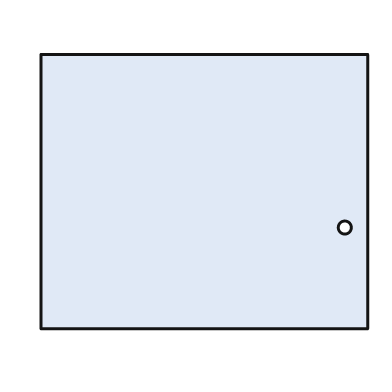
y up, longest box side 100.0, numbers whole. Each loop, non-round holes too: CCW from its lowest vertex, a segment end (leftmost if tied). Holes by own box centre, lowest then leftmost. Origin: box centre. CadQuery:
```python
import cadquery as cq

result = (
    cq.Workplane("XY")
    .moveTo(-50.0, -42.0)
    .lineTo(50.0, -42.0)
    .lineTo(50.0, 42.0)
    .lineTo(-50.0, 42.0)
    .close()
    .moveTo(43.0, -11.0)
    .circle(2.0)
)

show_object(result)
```